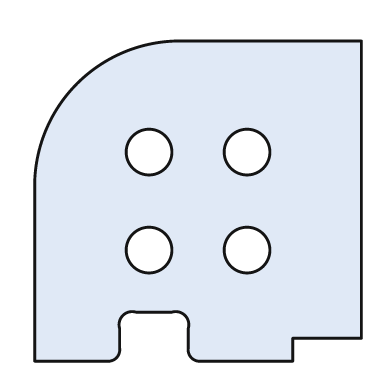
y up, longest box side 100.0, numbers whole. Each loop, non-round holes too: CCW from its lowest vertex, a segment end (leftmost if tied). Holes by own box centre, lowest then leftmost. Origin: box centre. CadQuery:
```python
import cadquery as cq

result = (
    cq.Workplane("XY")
    .moveTo(-50.0, -49.0)
    .lineTo(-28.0, -49.0)
    .threePointArc((-25.0, -48.0), (-24.0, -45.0))
    .lineTo(-24.0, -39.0)
    .threePointArc((-23.0, -35.0), (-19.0, -34.0))
    .lineTo(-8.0, -34.0)
    .threePointArc((-4.0, -35.0), (-3.0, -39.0))
    .lineTo(-3.0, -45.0)
    .threePointArc((-2.0, -48.0), (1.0, -49.0))
    .lineTo(29.0, -49.0)
    .lineTo(29.0, -42.0)
    .lineTo(50.0, -42.0)
    .lineTo(50.0, 49.0)
    .lineTo(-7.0, 49.0)
    .threePointArc((-37.0, 36.0), (-50.0, 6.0))
    .close()
    .moveTo(-15.0, -15.0)
    .circle(7.0)
    .moveTo(15.0, -15.0)
    .circle(7.0)
    .moveTo(-15.0, 15.0)
    .circle(7.0)
    .moveTo(15.0, 15.0)
    .circle(7.0)
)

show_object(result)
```